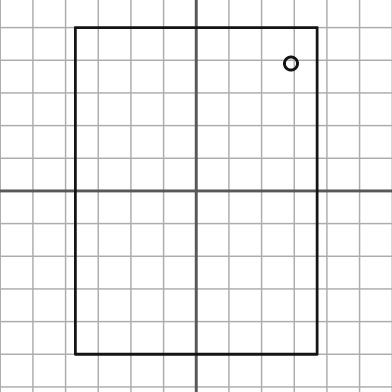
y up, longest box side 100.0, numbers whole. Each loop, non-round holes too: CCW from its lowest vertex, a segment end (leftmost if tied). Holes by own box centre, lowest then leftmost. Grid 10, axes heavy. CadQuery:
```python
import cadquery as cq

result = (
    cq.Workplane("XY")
    .moveTo(-37.0, -50.0)
    .lineTo(37.0, -50.0)
    .lineTo(37.0, 50.0)
    .lineTo(-37.0, 50.0)
    .close()
    .moveTo(29.0, 39.0)
    .circle(2.0)
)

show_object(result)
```